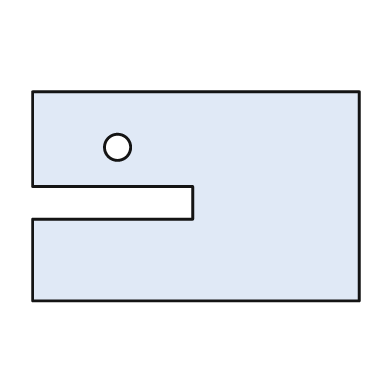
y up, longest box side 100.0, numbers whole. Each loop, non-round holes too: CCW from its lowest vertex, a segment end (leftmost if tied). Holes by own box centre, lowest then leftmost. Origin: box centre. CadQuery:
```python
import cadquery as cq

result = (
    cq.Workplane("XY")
    .moveTo(-50.0, -32.0)
    .lineTo(50.0, -32.0)
    .lineTo(50.0, 32.0)
    .lineTo(-50.0, 32.0)
    .lineTo(-50.0, 3.0)
    .lineTo(-1.0, 3.0)
    .lineTo(-1.0, -7.0)
    .lineTo(-50.0, -7.0)
    .close()
    .moveTo(-24.0, 15.0)
    .circle(4.0)
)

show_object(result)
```